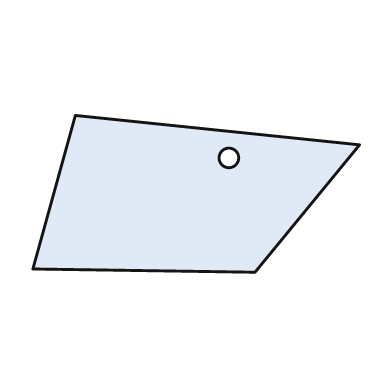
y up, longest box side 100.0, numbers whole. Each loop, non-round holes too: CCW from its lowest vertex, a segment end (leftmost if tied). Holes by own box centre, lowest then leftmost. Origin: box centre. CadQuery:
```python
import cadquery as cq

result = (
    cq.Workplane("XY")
    .moveTo(18.0, -24.0)
    .lineTo(50.0, 15.0)
    .lineTo(-37.0, 24.0)
    .lineTo(-50.0, -23.0)
    .close()
    .moveTo(10.0, 11.0)
    .circle(3.0)
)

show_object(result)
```